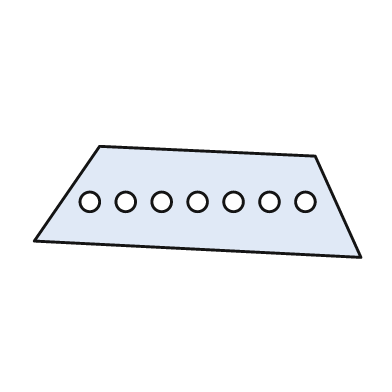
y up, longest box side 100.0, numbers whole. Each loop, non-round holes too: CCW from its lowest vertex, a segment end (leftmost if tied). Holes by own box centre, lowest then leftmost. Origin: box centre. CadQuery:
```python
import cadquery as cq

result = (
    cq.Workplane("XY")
    .moveTo(50.0, -17.0)
    .lineTo(36.0, 14.0)
    .lineTo(-30.0, 17.0)
    .lineTo(-50.0, -12.0)
    .close()
    .moveTo(-33.0, 0.0)
    .circle(3.0)
    .moveTo(-22.0, 0.0)
    .circle(3.0)
    .moveTo(-11.0, 0.0)
    .circle(3.0)
    .moveTo(0.0, 0.0)
    .circle(3.0)
    .moveTo(11.0, 0.0)
    .circle(3.0)
    .moveTo(22.0, 0.0)
    .circle(3.0)
    .moveTo(33.0, 0.0)
    .circle(3.0)
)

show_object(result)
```